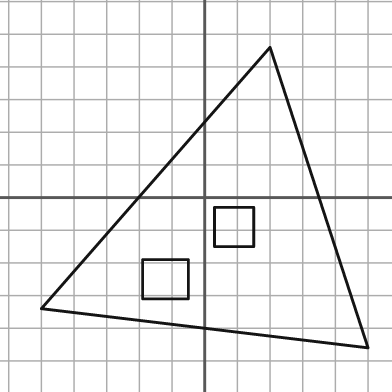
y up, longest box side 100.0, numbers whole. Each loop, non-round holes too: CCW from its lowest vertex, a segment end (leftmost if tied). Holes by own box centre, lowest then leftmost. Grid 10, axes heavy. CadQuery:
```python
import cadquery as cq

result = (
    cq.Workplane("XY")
    .moveTo(50.0, -46.0)
    .lineTo(20.0, 46.0)
    .lineTo(-50.0, -34.0)
    .close()
    .moveTo(-19.0, -31.0)
    .lineTo(-5.0, -31.0)
    .lineTo(-5.0, -19.0)
    .lineTo(-19.0, -19.0)
    .close()
    .moveTo(3.0, -15.0)
    .lineTo(15.0, -15.0)
    .lineTo(15.0, -3.0)
    .lineTo(3.0, -3.0)
    .close()
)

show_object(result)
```